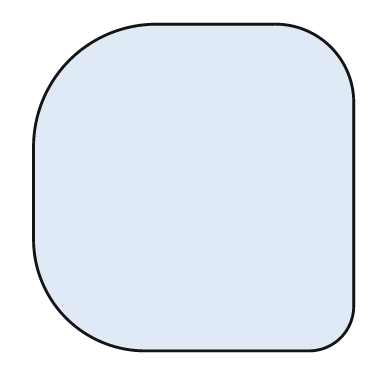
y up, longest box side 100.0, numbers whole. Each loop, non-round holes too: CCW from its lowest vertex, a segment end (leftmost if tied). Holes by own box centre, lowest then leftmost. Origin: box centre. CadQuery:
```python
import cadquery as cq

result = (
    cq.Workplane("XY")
    .moveTo(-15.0, -50.0)
    .lineTo(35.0, -50.0)
    .threePointArc((45.0, -46.0), (49.0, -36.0))
    .lineTo(49.0, 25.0)
    .threePointArc((42.0, 43.0), (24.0, 50.0))
    .lineTo(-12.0, 50.0)
    .threePointArc((-38.0, 39.0), (-49.0, 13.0))
    .lineTo(-49.0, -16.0)
    .threePointArc((-39.0, -40.0), (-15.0, -50.0))
    .close()
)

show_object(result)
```